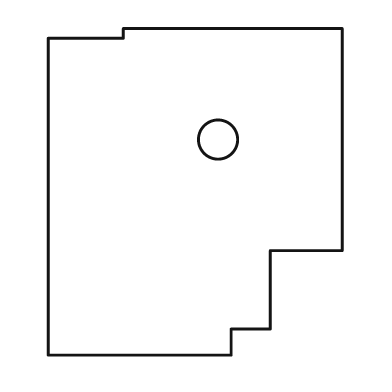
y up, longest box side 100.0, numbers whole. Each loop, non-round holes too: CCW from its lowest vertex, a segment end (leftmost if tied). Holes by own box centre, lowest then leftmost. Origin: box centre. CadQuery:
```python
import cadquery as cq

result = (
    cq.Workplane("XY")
    .moveTo(-45.0, -50.0)
    .lineTo(11.0, -50.0)
    .lineTo(11.0, -42.0)
    .lineTo(23.0, -42.0)
    .lineTo(23.0, -18.0)
    .lineTo(45.0, -18.0)
    .lineTo(45.0, 50.0)
    .lineTo(-22.0, 50.0)
    .lineTo(-22.0, 47.0)
    .lineTo(-45.0, 47.0)
    .close()
    .moveTo(7.0, 16.0)
    .circle(6.0)
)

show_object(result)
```